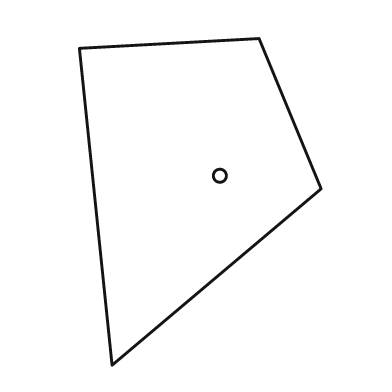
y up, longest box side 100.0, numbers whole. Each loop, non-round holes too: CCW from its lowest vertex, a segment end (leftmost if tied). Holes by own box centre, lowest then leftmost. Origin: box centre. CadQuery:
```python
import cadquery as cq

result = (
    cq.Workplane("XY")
    .moveTo(-27.0, -50.0)
    .lineTo(37.0, 4.0)
    .lineTo(18.0, 50.0)
    .lineTo(-37.0, 47.0)
    .close()
    .moveTo(6.0, 8.0)
    .circle(2.0)
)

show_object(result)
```